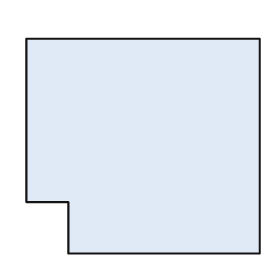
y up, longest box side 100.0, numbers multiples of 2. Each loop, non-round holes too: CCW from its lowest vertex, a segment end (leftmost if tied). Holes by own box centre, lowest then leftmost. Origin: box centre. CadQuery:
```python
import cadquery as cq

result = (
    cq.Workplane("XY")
    .moveTo(-32.0, -46.0)
    .lineTo(50.0, -46.0)
    .lineTo(50.0, 46.0)
    .lineTo(-50.0, 46.0)
    .lineTo(-50.0, -24.0)
    .lineTo(-32.0, -24.0)
    .close()
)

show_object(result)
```